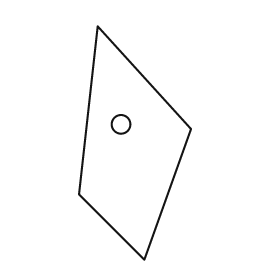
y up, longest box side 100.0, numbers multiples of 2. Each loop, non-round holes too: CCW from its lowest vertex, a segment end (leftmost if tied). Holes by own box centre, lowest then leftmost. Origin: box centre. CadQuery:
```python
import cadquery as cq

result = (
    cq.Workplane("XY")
    .moveTo(4.0, -50.0)
    .lineTo(24.0, 6.0)
    .lineTo(-16.0, 50.0)
    .lineTo(-24.0, -22.0)
    .close()
    .moveTo(-6.0, 8.0)
    .circle(4.0)
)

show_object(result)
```